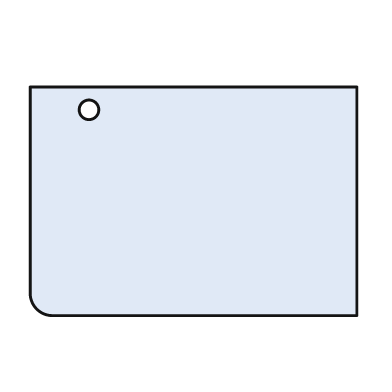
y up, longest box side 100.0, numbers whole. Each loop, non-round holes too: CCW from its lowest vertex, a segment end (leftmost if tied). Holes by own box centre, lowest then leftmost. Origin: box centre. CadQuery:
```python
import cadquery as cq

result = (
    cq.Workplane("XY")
    .moveTo(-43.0, -35.0)
    .lineTo(50.0, -35.0)
    .lineTo(50.0, 35.0)
    .lineTo(-50.0, 35.0)
    .lineTo(-50.0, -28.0)
    .threePointArc((-48.0, -33.0), (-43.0, -35.0))
    .close()
    .moveTo(-32.0, 28.0)
    .circle(3.0)
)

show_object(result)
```